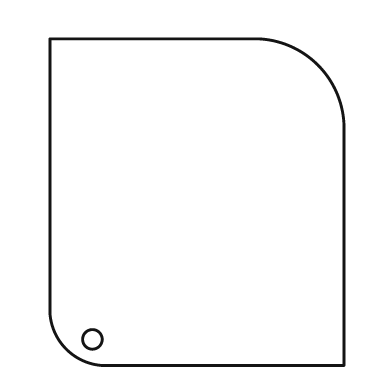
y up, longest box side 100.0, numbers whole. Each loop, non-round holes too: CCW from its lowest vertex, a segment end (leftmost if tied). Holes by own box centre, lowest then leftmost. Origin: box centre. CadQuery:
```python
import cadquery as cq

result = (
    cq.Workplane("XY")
    .moveTo(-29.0, -50.0)
    .lineTo(45.0, -50.0)
    .lineTo(45.0, 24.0)
    .threePointArc((37.0, 42.0), (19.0, 50.0))
    .lineTo(-45.0, 50.0)
    .lineTo(-45.0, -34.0)
    .threePointArc((-40.0, -45.0), (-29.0, -50.0))
    .close()
    .moveTo(-32.0, -42.0)
    .circle(3.0)
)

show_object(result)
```